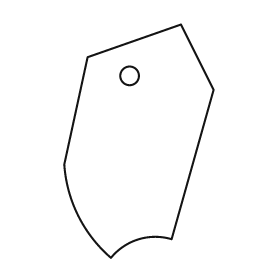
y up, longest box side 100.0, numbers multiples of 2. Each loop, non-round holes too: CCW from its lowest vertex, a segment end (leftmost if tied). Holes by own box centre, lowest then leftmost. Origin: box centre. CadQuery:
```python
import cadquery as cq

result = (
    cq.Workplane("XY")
    .moveTo(-12.0, -50.0)
    .threePointArc((0.0, -42.0), (14.0, -42.0))
    .lineTo(32.0, 22.0)
    .lineTo(18.0, 50.0)
    .lineTo(-22.0, 36.0)
    .lineTo(-32.0, -10.0)
    .threePointArc((-26.0, -32.0), (-12.0, -50.0))
    .close()
    .moveTo(-4.0, 28.0)
    .circle(4.0)
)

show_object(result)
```